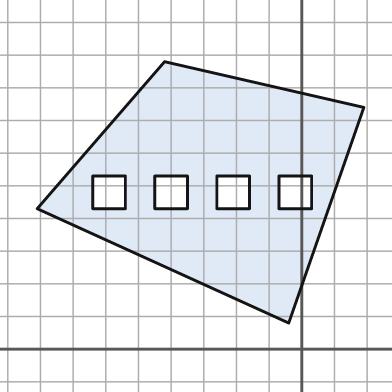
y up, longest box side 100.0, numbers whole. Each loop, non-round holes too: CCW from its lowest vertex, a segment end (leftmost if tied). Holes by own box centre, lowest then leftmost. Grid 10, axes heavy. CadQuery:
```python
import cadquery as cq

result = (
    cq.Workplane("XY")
    .moveTo(-4.0, 8.0)
    .lineTo(19.0, 74.0)
    .lineTo(-42.0, 88.0)
    .lineTo(-81.0, 43.0)
    .close()
    .moveTo(-64.0, 43.0)
    .lineTo(-54.0, 43.0)
    .lineTo(-54.0, 53.0)
    .lineTo(-64.0, 53.0)
    .close()
    .moveTo(-45.0, 43.0)
    .lineTo(-35.0, 43.0)
    .lineTo(-35.0, 53.0)
    .lineTo(-45.0, 53.0)
    .close()
    .moveTo(-26.0, 43.0)
    .lineTo(-16.0, 43.0)
    .lineTo(-16.0, 53.0)
    .lineTo(-26.0, 53.0)
    .close()
    .moveTo(-7.0, 43.0)
    .lineTo(3.0, 43.0)
    .lineTo(3.0, 53.0)
    .lineTo(-7.0, 53.0)
    .close()
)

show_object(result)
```